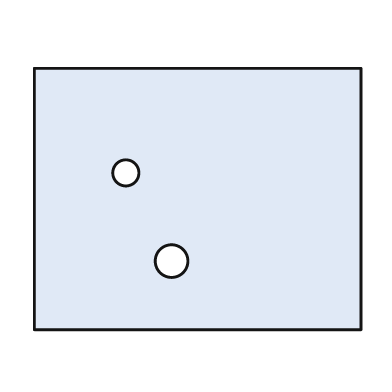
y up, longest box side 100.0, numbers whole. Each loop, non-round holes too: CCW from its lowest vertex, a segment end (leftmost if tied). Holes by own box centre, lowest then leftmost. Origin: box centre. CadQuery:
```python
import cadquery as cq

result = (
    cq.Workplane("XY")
    .moveTo(-50.0, -40.0)
    .lineTo(50.0, -40.0)
    .lineTo(50.0, 40.0)
    .lineTo(-50.0, 40.0)
    .close()
    .moveTo(-8.0, -19.0)
    .circle(5.0)
    .moveTo(-22.0, 8.0)
    .circle(4.0)
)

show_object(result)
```